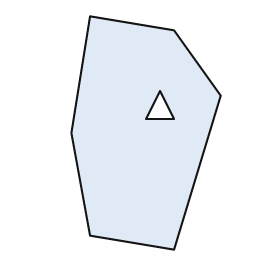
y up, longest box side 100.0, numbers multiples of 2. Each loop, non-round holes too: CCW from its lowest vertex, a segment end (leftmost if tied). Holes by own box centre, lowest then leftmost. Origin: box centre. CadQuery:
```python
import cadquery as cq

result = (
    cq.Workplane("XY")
    .moveTo(12.0, -50.0)
    .lineTo(32.0, 16.0)
    .lineTo(12.0, 44.0)
    .lineTo(-24.0, 50.0)
    .lineTo(-32.0, 0.0)
    .lineTo(-24.0, -44.0)
    .close()
    .moveTo(0.0, 6.0)
    .lineTo(12.0, 6.0)
    .lineTo(6.0, 18.0)
    .close()
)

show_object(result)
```